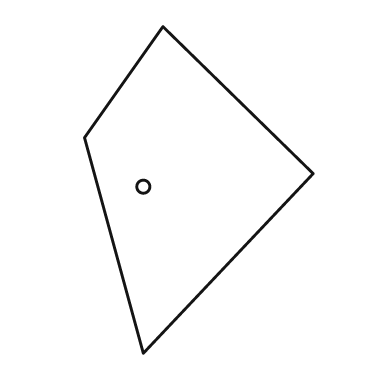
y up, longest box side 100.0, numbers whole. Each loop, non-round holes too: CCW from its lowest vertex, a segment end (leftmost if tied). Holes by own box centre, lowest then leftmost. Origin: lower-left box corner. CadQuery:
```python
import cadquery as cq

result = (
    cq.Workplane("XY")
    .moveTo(18.0, 0.0)
    .lineTo(70.0, 55.0)
    .lineTo(24.0, 100.0)
    .lineTo(0.0, 66.0)
    .close()
    .moveTo(18.0, 51.0)
    .circle(2.0)
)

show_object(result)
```